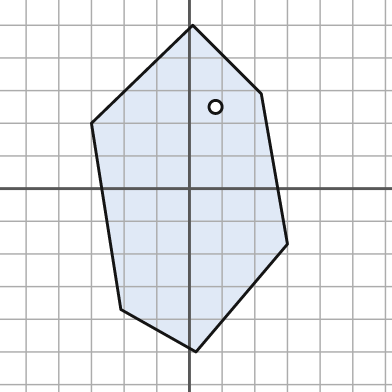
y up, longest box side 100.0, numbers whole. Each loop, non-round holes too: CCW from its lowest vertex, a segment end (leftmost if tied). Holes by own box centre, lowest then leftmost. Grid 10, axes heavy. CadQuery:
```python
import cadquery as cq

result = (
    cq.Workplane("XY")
    .moveTo(2.0, -50.0)
    .lineTo(30.0, -17.0)
    .lineTo(22.0, 29.0)
    .lineTo(1.0, 50.0)
    .lineTo(-30.0, 20.0)
    .lineTo(-21.0, -37.0)
    .close()
    .moveTo(8.0, 25.0)
    .circle(2.0)
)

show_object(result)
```